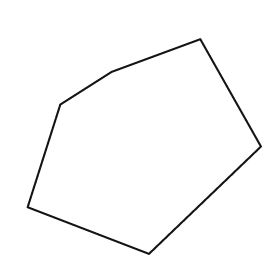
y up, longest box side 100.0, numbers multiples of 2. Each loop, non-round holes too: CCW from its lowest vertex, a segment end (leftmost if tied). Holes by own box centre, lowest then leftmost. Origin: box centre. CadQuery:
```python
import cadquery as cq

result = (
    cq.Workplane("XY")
    .moveTo(2.0, -46.0)
    .lineTo(50.0, 0.0)
    .lineTo(24.0, 46.0)
    .lineTo(-14.0, 32.0)
    .lineTo(-36.0, 18.0)
    .lineTo(-50.0, -26.0)
    .close()
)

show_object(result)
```